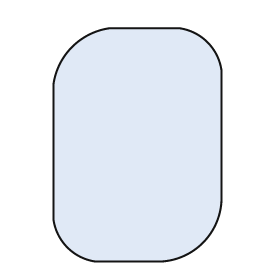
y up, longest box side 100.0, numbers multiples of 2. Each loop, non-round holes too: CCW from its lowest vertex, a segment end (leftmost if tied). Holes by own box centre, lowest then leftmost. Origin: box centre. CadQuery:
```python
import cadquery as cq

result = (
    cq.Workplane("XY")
    .moveTo(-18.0, -50.0)
    .lineTo(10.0, -50.0)
    .threePointArc((28.0, -42.0), (36.0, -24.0))
    .lineTo(36.0, 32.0)
    .threePointArc((30.0, 44.0), (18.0, 50.0))
    .lineTo(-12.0, 50.0)
    .threePointArc((-28.0, 42.0), (-36.0, 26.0))
    .lineTo(-36.0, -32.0)
    .threePointArc((-30.0, -44.0), (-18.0, -50.0))
    .close()
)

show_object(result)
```